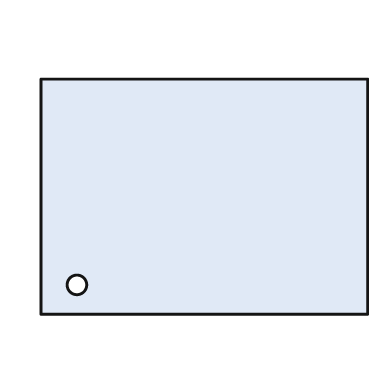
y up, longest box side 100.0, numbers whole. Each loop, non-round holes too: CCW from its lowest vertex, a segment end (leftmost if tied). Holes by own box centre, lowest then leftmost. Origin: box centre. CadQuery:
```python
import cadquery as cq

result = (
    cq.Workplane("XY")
    .moveTo(-50.0, -36.0)
    .lineTo(50.0, -36.0)
    .lineTo(50.0, 36.0)
    .lineTo(-50.0, 36.0)
    .close()
    .moveTo(-39.0, -27.0)
    .circle(3.0)
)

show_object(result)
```